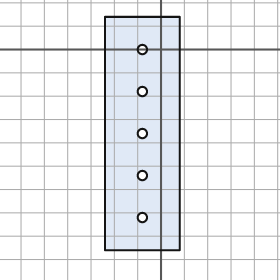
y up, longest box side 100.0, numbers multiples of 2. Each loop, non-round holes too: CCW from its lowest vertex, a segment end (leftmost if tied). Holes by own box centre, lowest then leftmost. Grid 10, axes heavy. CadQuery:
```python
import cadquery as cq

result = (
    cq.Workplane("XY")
    .moveTo(-24.0, -86.0)
    .lineTo(8.0, -86.0)
    .lineTo(8.0, 14.0)
    .lineTo(-24.0, 14.0)
    .close()
    .moveTo(-8.0, -72.0)
    .circle(2.0)
    .moveTo(-8.0, -54.0)
    .circle(2.0)
    .moveTo(-8.0, -36.0)
    .circle(2.0)
    .moveTo(-8.0, -18.0)
    .circle(2.0)
    .moveTo(-8.0, 0.0)
    .circle(2.0)
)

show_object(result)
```